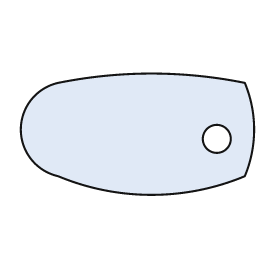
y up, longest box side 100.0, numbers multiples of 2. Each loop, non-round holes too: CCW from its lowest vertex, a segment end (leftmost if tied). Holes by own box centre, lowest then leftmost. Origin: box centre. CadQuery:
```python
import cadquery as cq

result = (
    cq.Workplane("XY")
    .moveTo(-34.0, -18.0)
    .threePointArc((6.0, -26.0), (46.0, -18.0))
    .threePointArc((50.0, 2.0), (46.0, 22.0))
    .threePointArc((6.0, 26.0), (-34.0, 22.0))
    .threePointArc((-50.0, 2.0), (-34.0, -18.0))
    .close()
    .moveTo(34.0, -2.0)
    .circle(6.0)
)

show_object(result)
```